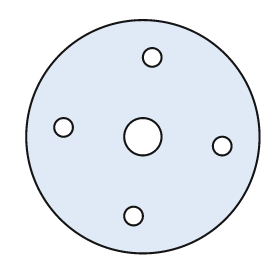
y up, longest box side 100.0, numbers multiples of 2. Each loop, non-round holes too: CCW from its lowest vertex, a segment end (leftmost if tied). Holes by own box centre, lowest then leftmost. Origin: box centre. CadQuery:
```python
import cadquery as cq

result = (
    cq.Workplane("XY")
    .moveTo(0.0, 0.0)
    .circle(50.0)
    .moveTo(-4.0, -34.0)
    .circle(4.0)
    .moveTo(34.0, -4.0)
    .circle(4.0)
    .moveTo(0.0, 0.0)
    .circle(8.0)
    .moveTo(-34.0, 4.0)
    .circle(4.0)
    .moveTo(4.0, 34.0)
    .circle(4.0)
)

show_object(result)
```